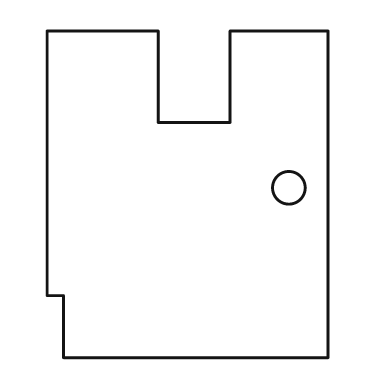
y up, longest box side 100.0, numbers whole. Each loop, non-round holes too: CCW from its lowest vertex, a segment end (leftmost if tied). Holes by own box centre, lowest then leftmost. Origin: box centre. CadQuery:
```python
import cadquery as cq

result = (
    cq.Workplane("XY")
    .moveTo(-38.0, -50.0)
    .lineTo(43.0, -50.0)
    .lineTo(43.0, 50.0)
    .lineTo(13.0, 50.0)
    .lineTo(13.0, 22.0)
    .lineTo(-9.0, 22.0)
    .lineTo(-9.0, 50.0)
    .lineTo(-43.0, 50.0)
    .lineTo(-43.0, -31.0)
    .lineTo(-38.0, -31.0)
    .close()
    .moveTo(31.0, 2.0)
    .circle(5.0)
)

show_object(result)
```